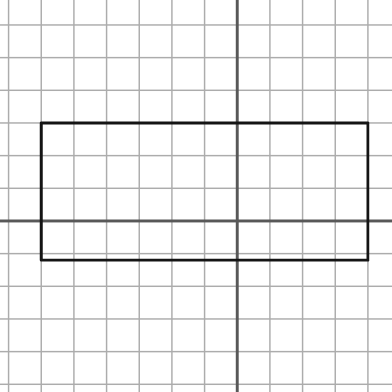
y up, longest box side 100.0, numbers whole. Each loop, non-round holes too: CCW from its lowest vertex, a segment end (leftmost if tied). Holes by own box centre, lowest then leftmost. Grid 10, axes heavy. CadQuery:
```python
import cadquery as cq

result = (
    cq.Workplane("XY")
    .moveTo(-60.0, -12.0)
    .lineTo(40.0, -12.0)
    .lineTo(40.0, 30.0)
    .lineTo(-60.0, 30.0)
    .close()
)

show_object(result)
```